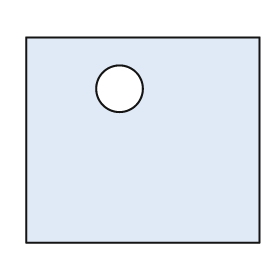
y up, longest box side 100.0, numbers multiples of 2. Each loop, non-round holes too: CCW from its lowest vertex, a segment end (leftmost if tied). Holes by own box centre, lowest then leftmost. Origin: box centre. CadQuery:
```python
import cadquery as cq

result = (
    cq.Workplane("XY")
    .moveTo(-50.0, -44.0)
    .lineTo(50.0, -44.0)
    .lineTo(50.0, 44.0)
    .lineTo(-50.0, 44.0)
    .close()
    .moveTo(-10.0, 22.0)
    .circle(10.0)
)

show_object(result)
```